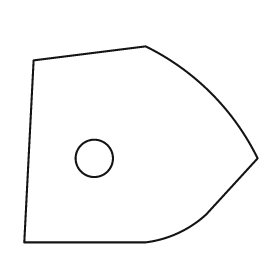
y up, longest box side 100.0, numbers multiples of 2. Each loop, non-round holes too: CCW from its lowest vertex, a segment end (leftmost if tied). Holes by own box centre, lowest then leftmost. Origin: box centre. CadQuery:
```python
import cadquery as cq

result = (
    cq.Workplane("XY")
    .moveTo(-50.0, -42.0)
    .lineTo(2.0, -42.0)
    .threePointArc((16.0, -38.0), (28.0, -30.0))
    .lineTo(50.0, -6.0)
    .threePointArc((30.0, 22.0), (2.0, 42.0))
    .lineTo(-46.0, 36.0)
    .close()
    .moveTo(-20.0, -6.0)
    .circle(8.0)
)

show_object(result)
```